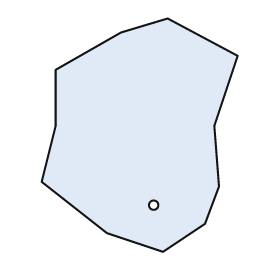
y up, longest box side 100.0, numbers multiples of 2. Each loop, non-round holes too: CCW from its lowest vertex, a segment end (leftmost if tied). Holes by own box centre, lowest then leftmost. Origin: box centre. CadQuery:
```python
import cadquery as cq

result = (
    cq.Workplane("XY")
    .moveTo(10.0, -50.0)
    .lineTo(28.0, -38.0)
    .lineTo(34.0, -22.0)
    .lineTo(32.0, 4.0)
    .lineTo(42.0, 34.0)
    .lineTo(12.0, 50.0)
    .lineTo(-8.0, 44.0)
    .lineTo(-36.0, 28.0)
    .lineTo(-36.0, 4.0)
    .lineTo(-42.0, -20.0)
    .lineTo(-14.0, -42.0)
    .close()
    .moveTo(6.0, -30.0)
    .circle(2.0)
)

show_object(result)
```